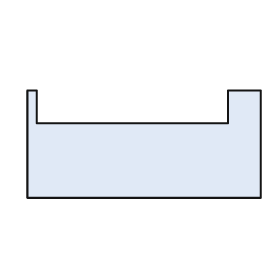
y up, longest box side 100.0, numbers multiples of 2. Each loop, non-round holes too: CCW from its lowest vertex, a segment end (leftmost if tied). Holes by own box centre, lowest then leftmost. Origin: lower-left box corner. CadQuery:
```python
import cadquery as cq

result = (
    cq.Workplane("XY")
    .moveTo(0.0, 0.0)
    .lineTo(100.0, 0.0)
    .lineTo(100.0, 46.0)
    .lineTo(86.0, 46.0)
    .lineTo(86.0, 32.0)
    .lineTo(4.0, 32.0)
    .lineTo(4.0, 46.0)
    .lineTo(0.0, 46.0)
    .close()
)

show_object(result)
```